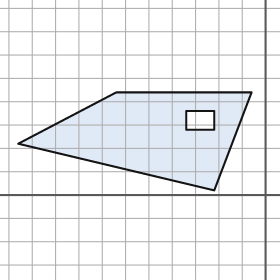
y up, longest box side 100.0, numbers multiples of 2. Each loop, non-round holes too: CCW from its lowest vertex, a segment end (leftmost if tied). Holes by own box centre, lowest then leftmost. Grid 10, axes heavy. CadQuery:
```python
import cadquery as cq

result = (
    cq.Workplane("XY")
    .moveTo(-22.0, 2.0)
    .lineTo(-6.0, 44.0)
    .lineTo(-64.0, 44.0)
    .lineTo(-106.0, 22.0)
    .close()
    .moveTo(-34.0, 28.0)
    .lineTo(-22.0, 28.0)
    .lineTo(-22.0, 36.0)
    .lineTo(-34.0, 36.0)
    .close()
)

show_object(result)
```